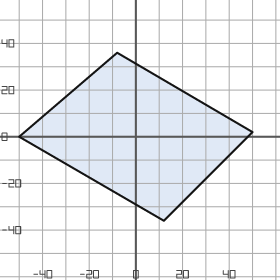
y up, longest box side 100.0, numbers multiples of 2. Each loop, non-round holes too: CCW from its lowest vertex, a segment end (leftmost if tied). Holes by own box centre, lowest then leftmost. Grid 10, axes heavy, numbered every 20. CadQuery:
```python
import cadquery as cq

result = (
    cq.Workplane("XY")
    .moveTo(12.0, -36.0)
    .lineTo(50.0, 2.0)
    .lineTo(-8.0, 36.0)
    .lineTo(-50.0, 0.0)
    .close()
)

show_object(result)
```